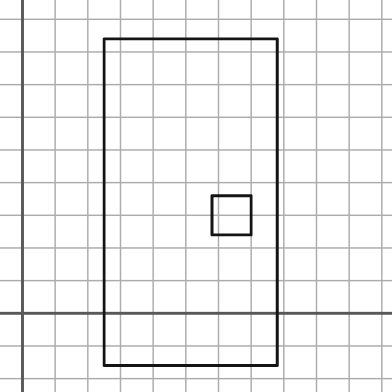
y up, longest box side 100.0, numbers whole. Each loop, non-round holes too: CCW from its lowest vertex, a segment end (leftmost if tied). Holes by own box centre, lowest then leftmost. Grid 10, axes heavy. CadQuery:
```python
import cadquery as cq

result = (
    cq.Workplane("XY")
    .moveTo(25.0, -16.0)
    .lineTo(78.0, -16.0)
    .lineTo(78.0, 84.0)
    .lineTo(25.0, 84.0)
    .close()
    .moveTo(58.0, 24.0)
    .lineTo(70.0, 24.0)
    .lineTo(70.0, 36.0)
    .lineTo(58.0, 36.0)
    .close()
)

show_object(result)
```